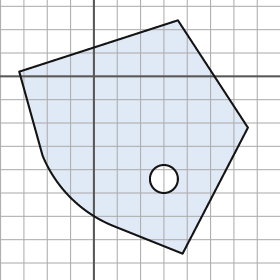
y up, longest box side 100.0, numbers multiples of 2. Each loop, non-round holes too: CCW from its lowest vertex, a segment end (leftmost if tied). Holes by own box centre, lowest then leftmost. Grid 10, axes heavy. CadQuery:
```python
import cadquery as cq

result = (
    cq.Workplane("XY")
    .moveTo(38.0, -76.0)
    .lineTo(66.0, -22.0)
    .lineTo(36.0, 24.0)
    .lineTo(-32.0, 2.0)
    .lineTo(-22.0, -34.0)
    .threePointArc((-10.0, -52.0), (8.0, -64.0))
    .close()
    .moveTo(30.0, -44.0)
    .circle(6.0)
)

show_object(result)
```